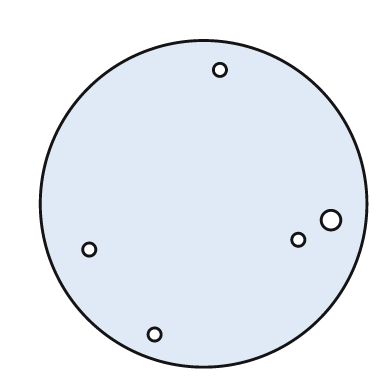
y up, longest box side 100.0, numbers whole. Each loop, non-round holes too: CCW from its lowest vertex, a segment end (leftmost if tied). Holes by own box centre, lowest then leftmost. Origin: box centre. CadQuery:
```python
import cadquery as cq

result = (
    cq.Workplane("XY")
    .moveTo(0.0, 0.0)
    .circle(50.0)
    .moveTo(-15.0, -40.0)
    .circle(2.0)
    .moveTo(-35.0, -14.0)
    .circle(2.0)
    .moveTo(29.0, -11.0)
    .circle(2.0)
    .moveTo(39.0, -5.0)
    .circle(3.0)
    .moveTo(5.0, 41.0)
    .circle(2.0)
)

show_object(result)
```